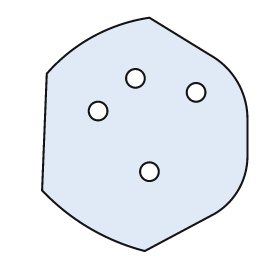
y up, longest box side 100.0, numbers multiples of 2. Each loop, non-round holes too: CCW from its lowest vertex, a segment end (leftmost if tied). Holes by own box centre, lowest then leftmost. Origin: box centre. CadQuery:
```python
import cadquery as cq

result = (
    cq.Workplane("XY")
    .moveTo(0.0, -50.0)
    .lineTo(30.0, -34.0)
    .threePointArc((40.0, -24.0), (44.0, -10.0))
    .lineTo(44.0, 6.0)
    .threePointArc((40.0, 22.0), (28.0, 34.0))
    .lineTo(2.0, 50.0)
    .threePointArc((-22.0, 42.0), (-42.0, 26.0))
    .lineTo(-44.0, -24.0)
    .threePointArc((-24.0, -40.0), (0.0, -50.0))
    .close()
    .moveTo(2.0, -16.0)
    .circle(4.0)
    .moveTo(-20.0, 10.0)
    .circle(4.0)
    .moveTo(22.0, 18.0)
    .circle(4.0)
    .moveTo(-4.0, 24.0)
    .circle(4.0)
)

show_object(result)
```